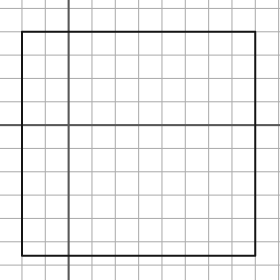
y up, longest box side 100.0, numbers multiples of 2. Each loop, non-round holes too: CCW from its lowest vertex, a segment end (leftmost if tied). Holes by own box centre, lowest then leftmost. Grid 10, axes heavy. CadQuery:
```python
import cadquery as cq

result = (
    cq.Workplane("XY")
    .moveTo(-20.0, -56.0)
    .lineTo(80.0, -56.0)
    .lineTo(80.0, 40.0)
    .lineTo(-20.0, 40.0)
    .close()
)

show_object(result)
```